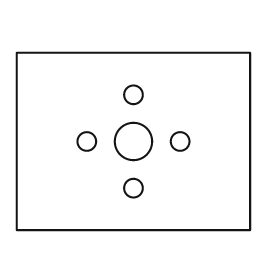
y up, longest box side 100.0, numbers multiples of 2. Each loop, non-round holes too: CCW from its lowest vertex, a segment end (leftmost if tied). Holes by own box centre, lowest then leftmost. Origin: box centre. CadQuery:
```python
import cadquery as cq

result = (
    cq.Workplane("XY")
    .moveTo(-50.0, -38.0)
    .lineTo(50.0, -38.0)
    .lineTo(50.0, 38.0)
    .lineTo(-50.0, 38.0)
    .close()
    .moveTo(0.0, -20.0)
    .circle(4.0)
    .moveTo(-20.0, 0.0)
    .circle(4.0)
    .moveTo(0.0, 0.0)
    .circle(8.0)
    .moveTo(20.0, 0.0)
    .circle(4.0)
    .moveTo(0.0, 20.0)
    .circle(4.0)
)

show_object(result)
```